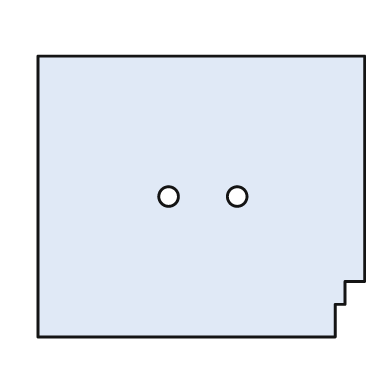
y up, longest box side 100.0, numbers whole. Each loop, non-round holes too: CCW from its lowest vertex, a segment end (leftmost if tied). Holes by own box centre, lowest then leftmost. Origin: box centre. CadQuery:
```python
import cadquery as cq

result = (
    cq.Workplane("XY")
    .moveTo(-50.0, -43.0)
    .lineTo(41.0, -43.0)
    .lineTo(41.0, -33.0)
    .lineTo(44.0, -33.0)
    .lineTo(44.0, -26.0)
    .lineTo(50.0, -26.0)
    .lineTo(50.0, 43.0)
    .lineTo(-50.0, 43.0)
    .close()
    .moveTo(-10.0, 0.0)
    .circle(3.0)
    .moveTo(11.0, 0.0)
    .circle(3.0)
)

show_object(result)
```